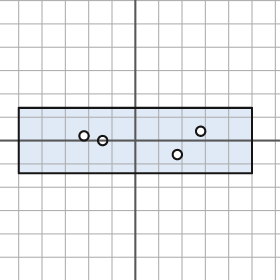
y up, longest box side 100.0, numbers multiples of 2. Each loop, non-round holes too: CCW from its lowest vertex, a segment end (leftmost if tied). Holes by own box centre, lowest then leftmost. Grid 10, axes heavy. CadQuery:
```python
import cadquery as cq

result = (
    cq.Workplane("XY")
    .moveTo(-50.0, -14.0)
    .lineTo(50.0, -14.0)
    .lineTo(50.0, 14.0)
    .lineTo(-50.0, 14.0)
    .close()
    .moveTo(18.0, -6.0)
    .circle(2.0)
    .moveTo(-14.0, 0.0)
    .circle(2.0)
    .moveTo(-22.0, 2.0)
    .circle(2.0)
    .moveTo(28.0, 4.0)
    .circle(2.0)
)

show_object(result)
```